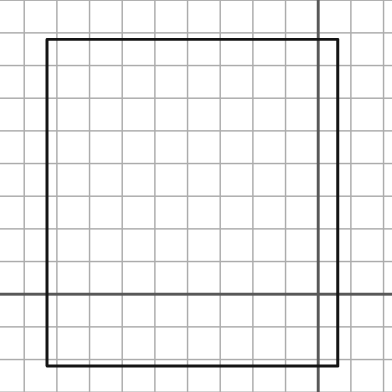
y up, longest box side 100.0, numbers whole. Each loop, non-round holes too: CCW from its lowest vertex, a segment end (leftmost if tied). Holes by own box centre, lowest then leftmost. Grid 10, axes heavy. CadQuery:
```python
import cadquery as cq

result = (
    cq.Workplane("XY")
    .moveTo(-83.0, -22.0)
    .lineTo(6.0, -22.0)
    .lineTo(6.0, 78.0)
    .lineTo(-83.0, 78.0)
    .close()
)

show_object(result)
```